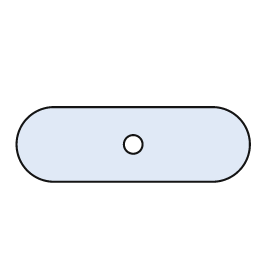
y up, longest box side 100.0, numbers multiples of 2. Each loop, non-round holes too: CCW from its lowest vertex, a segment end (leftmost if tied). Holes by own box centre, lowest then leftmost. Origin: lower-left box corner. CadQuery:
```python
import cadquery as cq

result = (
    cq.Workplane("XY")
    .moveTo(16.0, 0.0)
    .lineTo(84.0, 0.0)
    .threePointArc((100.0, 16.0), (84.0, 32.0))
    .lineTo(16.0, 32.0)
    .threePointArc((0.0, 16.0), (16.0, 0.0))
    .close()
    .moveTo(50.0, 16.0)
    .circle(4.0)
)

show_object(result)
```